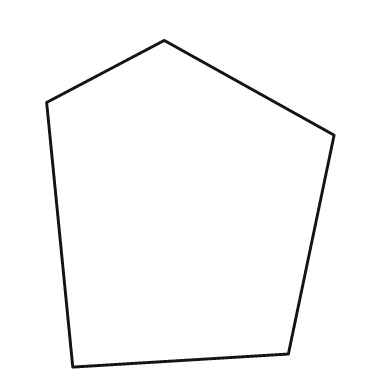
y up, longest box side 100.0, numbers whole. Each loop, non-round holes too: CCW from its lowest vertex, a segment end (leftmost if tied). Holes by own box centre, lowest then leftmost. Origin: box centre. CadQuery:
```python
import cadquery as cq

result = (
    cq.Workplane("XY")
    .moveTo(-36.0, -50.0)
    .lineTo(30.0, -46.0)
    .lineTo(44.0, 21.0)
    .lineTo(-8.0, 50.0)
    .lineTo(-44.0, 31.0)
    .close()
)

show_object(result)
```